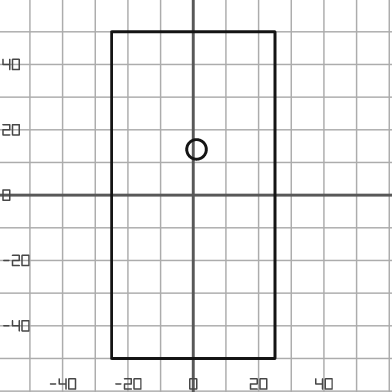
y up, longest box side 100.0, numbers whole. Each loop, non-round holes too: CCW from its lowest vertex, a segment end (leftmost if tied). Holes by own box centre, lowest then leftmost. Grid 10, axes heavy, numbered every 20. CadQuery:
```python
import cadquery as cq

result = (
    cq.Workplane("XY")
    .moveTo(-25.0, -50.0)
    .lineTo(25.0, -50.0)
    .lineTo(25.0, 50.0)
    .lineTo(-25.0, 50.0)
    .close()
    .moveTo(1.0, 14.0)
    .circle(3.0)
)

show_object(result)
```